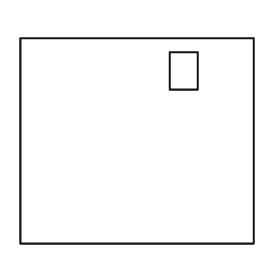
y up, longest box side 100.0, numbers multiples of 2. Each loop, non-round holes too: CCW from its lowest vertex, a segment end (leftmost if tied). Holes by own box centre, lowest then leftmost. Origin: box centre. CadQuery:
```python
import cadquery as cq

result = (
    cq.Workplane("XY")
    .moveTo(-50.0, -44.0)
    .lineTo(50.0, -44.0)
    .lineTo(50.0, 44.0)
    .lineTo(-50.0, 44.0)
    .close()
    .moveTo(14.0, 22.0)
    .lineTo(26.0, 22.0)
    .lineTo(26.0, 38.0)
    .lineTo(14.0, 38.0)
    .close()
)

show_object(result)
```